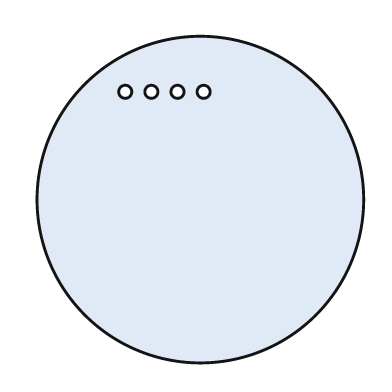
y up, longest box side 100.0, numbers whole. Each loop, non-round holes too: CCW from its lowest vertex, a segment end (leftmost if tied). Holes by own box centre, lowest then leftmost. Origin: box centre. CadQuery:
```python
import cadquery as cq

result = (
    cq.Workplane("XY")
    .moveTo(0.0, 0.0)
    .circle(50.0)
    .moveTo(-23.0, 33.0)
    .circle(2.0)
    .moveTo(-15.0, 33.0)
    .circle(2.0)
    .moveTo(-7.0, 33.0)
    .circle(2.0)
    .moveTo(1.0, 33.0)
    .circle(2.0)
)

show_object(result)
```